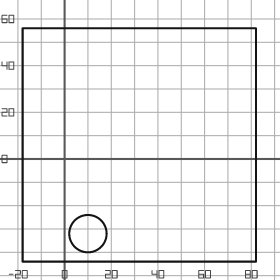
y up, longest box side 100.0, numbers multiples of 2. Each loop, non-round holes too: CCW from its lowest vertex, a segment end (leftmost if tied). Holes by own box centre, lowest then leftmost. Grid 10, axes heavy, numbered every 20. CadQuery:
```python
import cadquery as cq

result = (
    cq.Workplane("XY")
    .moveTo(-18.0, -44.0)
    .lineTo(82.0, -44.0)
    .lineTo(82.0, 56.0)
    .lineTo(-18.0, 56.0)
    .close()
    .moveTo(10.0, -32.0)
    .circle(8.0)
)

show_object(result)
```